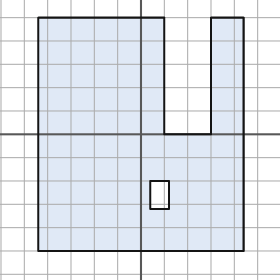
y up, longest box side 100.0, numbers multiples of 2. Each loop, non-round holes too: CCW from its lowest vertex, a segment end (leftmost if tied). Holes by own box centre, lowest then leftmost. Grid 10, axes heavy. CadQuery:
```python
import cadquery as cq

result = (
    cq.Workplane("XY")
    .moveTo(-44.0, -50.0)
    .lineTo(44.0, -50.0)
    .lineTo(44.0, 50.0)
    .lineTo(30.0, 50.0)
    .lineTo(30.0, 0.0)
    .lineTo(10.0, 0.0)
    .lineTo(10.0, 50.0)
    .lineTo(-44.0, 50.0)
    .close()
    .moveTo(4.0, -32.0)
    .lineTo(12.0, -32.0)
    .lineTo(12.0, -20.0)
    .lineTo(4.0, -20.0)
    .close()
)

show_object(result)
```